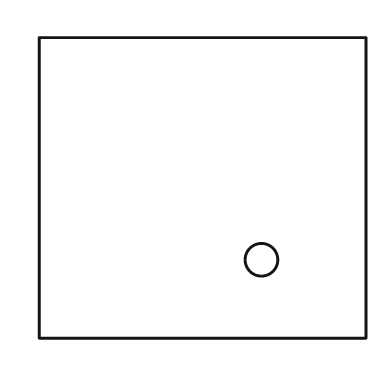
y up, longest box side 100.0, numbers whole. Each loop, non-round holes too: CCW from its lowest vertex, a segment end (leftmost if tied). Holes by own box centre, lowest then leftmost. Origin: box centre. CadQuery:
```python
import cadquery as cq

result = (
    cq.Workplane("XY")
    .moveTo(-50.0, -46.0)
    .lineTo(50.0, -46.0)
    .lineTo(50.0, 46.0)
    .lineTo(-50.0, 46.0)
    .close()
    .moveTo(18.0, -22.0)
    .circle(5.0)
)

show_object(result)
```